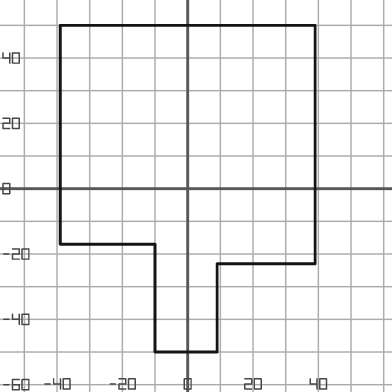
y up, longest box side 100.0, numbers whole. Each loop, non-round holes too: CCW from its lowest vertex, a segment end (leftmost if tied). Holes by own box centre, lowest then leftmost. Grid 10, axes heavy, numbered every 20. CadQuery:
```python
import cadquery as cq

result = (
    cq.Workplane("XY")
    .moveTo(-10.0, -50.0)
    .lineTo(9.0, -50.0)
    .lineTo(9.0, -23.0)
    .lineTo(39.0, -23.0)
    .lineTo(39.0, 50.0)
    .lineTo(-39.0, 50.0)
    .lineTo(-39.0, -17.0)
    .lineTo(-10.0, -17.0)
    .close()
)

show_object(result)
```